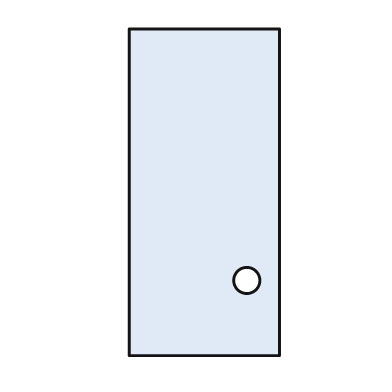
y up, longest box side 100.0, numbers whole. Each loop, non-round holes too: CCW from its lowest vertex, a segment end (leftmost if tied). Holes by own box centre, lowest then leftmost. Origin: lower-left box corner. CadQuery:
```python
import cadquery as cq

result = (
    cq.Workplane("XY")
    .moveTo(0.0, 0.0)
    .lineTo(46.0, 0.0)
    .lineTo(46.0, 100.0)
    .lineTo(0.0, 100.0)
    .close()
    .moveTo(36.0, 23.0)
    .circle(4.0)
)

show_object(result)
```